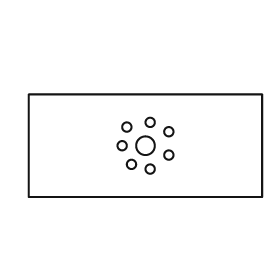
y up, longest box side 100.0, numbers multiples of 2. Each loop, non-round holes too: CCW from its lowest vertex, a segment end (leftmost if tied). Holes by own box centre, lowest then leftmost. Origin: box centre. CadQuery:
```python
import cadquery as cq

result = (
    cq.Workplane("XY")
    .moveTo(-50.0, -22.0)
    .lineTo(50.0, -22.0)
    .lineTo(50.0, 22.0)
    .lineTo(-50.0, 22.0)
    .close()
    .moveTo(2.0, -10.0)
    .circle(2.0)
    .moveTo(-6.0, -8.0)
    .circle(2.0)
    .moveTo(10.0, -4.0)
    .circle(2.0)
    .moveTo(-10.0, 0.0)
    .circle(2.0)
    .moveTo(0.0, 0.0)
    .circle(4.0)
    .moveTo(10.0, 6.0)
    .circle(2.0)
    .moveTo(-8.0, 8.0)
    .circle(2.0)
    .moveTo(2.0, 10.0)
    .circle(2.0)
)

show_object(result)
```